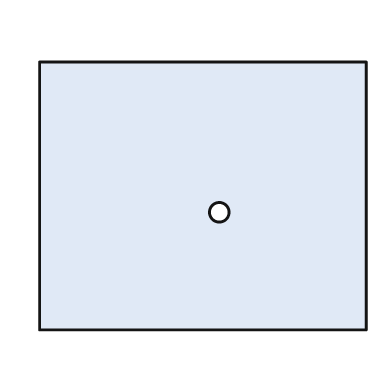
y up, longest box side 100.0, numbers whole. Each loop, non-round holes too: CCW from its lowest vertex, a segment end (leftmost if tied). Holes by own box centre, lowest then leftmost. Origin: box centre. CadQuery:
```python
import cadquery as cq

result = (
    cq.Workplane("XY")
    .moveTo(-50.0, -41.0)
    .lineTo(50.0, -41.0)
    .lineTo(50.0, 41.0)
    .lineTo(-50.0, 41.0)
    .close()
    .moveTo(5.0, -5.0)
    .circle(3.0)
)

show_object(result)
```